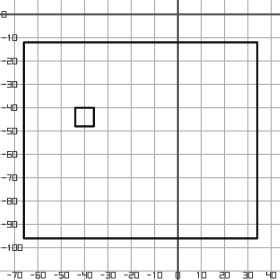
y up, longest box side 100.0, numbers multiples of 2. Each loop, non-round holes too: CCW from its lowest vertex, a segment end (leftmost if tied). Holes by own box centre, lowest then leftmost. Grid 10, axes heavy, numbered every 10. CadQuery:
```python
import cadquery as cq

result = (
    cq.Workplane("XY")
    .moveTo(-66.0, -96.0)
    .lineTo(34.0, -96.0)
    .lineTo(34.0, -12.0)
    .lineTo(-66.0, -12.0)
    .close()
    .moveTo(-44.0, -48.0)
    .lineTo(-36.0, -48.0)
    .lineTo(-36.0, -40.0)
    .lineTo(-44.0, -40.0)
    .close()
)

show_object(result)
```